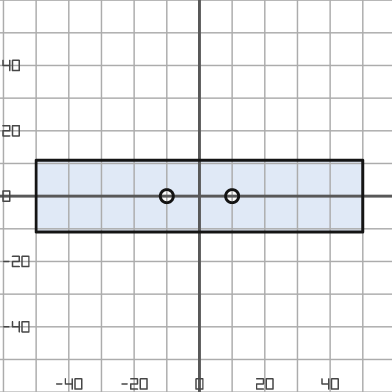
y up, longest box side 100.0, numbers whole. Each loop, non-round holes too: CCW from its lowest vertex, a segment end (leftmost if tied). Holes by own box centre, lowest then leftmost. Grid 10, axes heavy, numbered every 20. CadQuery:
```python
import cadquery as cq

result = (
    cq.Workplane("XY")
    .moveTo(-50.0, -11.0)
    .lineTo(50.0, -11.0)
    .lineTo(50.0, 11.0)
    .lineTo(-50.0, 11.0)
    .close()
    .moveTo(-10.0, 0.0)
    .circle(2.0)
    .moveTo(10.0, 0.0)
    .circle(2.0)
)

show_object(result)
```